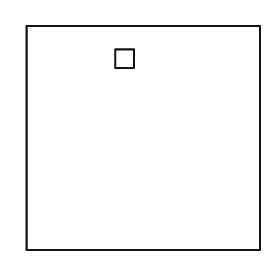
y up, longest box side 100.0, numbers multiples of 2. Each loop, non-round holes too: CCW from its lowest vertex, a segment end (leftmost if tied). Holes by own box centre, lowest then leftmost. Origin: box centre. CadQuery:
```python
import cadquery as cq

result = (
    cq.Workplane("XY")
    .moveTo(-50.0, -48.0)
    .lineTo(50.0, -48.0)
    .lineTo(50.0, 48.0)
    .lineTo(-50.0, 48.0)
    .close()
    .moveTo(-12.0, 30.0)
    .lineTo(-4.0, 30.0)
    .lineTo(-4.0, 38.0)
    .lineTo(-12.0, 38.0)
    .close()
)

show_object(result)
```